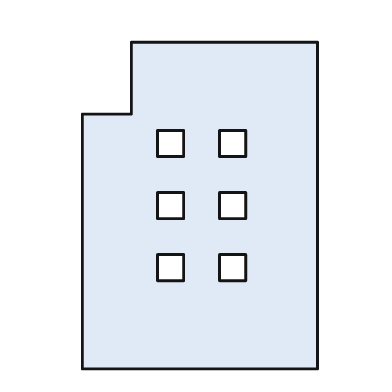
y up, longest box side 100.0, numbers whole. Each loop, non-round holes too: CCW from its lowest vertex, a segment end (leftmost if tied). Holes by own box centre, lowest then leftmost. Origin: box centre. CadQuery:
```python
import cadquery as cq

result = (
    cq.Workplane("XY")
    .moveTo(-36.0, -50.0)
    .lineTo(36.0, -50.0)
    .lineTo(36.0, 50.0)
    .lineTo(-21.0, 50.0)
    .lineTo(-21.0, 28.0)
    .lineTo(-36.0, 28.0)
    .close()
    .moveTo(-13.0, -23.0)
    .lineTo(-5.0, -23.0)
    .lineTo(-5.0, -15.0)
    .lineTo(-13.0, -15.0)
    .close()
    .moveTo(6.0, -23.0)
    .lineTo(14.0, -23.0)
    .lineTo(14.0, -15.0)
    .lineTo(6.0, -15.0)
    .close()
    .moveTo(-13.0, -4.0)
    .lineTo(-5.0, -4.0)
    .lineTo(-5.0, 4.0)
    .lineTo(-13.0, 4.0)
    .close()
    .moveTo(6.0, -4.0)
    .lineTo(14.0, -4.0)
    .lineTo(14.0, 4.0)
    .lineTo(6.0, 4.0)
    .close()
    .moveTo(-13.0, 15.0)
    .lineTo(-5.0, 15.0)
    .lineTo(-5.0, 23.0)
    .lineTo(-13.0, 23.0)
    .close()
    .moveTo(6.0, 15.0)
    .lineTo(14.0, 15.0)
    .lineTo(14.0, 23.0)
    .lineTo(6.0, 23.0)
    .close()
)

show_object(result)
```